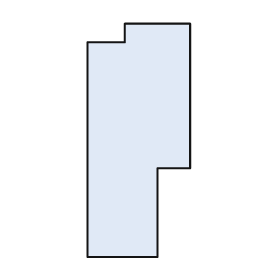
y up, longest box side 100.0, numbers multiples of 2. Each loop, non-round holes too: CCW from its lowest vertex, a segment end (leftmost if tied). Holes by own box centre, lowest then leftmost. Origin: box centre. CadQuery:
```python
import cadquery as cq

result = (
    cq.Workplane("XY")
    .moveTo(-22.0, -50.0)
    .lineTo(8.0, -50.0)
    .lineTo(8.0, -12.0)
    .lineTo(22.0, -12.0)
    .lineTo(22.0, 50.0)
    .lineTo(-6.0, 50.0)
    .lineTo(-6.0, 42.0)
    .lineTo(-22.0, 42.0)
    .close()
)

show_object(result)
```